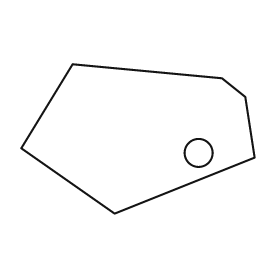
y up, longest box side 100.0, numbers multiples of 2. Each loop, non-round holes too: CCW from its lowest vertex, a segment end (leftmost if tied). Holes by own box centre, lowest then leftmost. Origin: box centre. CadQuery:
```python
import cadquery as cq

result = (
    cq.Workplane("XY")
    .moveTo(-10.0, -32.0)
    .lineTo(50.0, -8.0)
    .lineTo(46.0, 18.0)
    .lineTo(36.0, 26.0)
    .lineTo(-28.0, 32.0)
    .lineTo(-50.0, -4.0)
    .close()
    .moveTo(26.0, -6.0)
    .circle(6.0)
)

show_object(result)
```